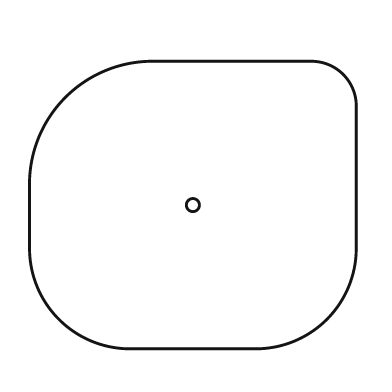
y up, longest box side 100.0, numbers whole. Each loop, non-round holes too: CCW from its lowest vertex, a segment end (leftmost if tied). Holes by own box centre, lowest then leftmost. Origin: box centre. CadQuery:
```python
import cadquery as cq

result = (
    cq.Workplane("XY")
    .moveTo(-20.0, -44.0)
    .lineTo(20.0, -44.0)
    .threePointArc((41.0, -35.0), (50.0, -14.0))
    .lineTo(50.0, 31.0)
    .threePointArc((46.0, 40.0), (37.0, 44.0))
    .lineTo(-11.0, 44.0)
    .threePointArc((-39.0, 33.0), (-50.0, 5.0))
    .lineTo(-50.0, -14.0)
    .threePointArc((-41.0, -35.0), (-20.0, -44.0))
    .close()
    .moveTo(0.0, 0.0)
    .circle(2.0)
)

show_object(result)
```